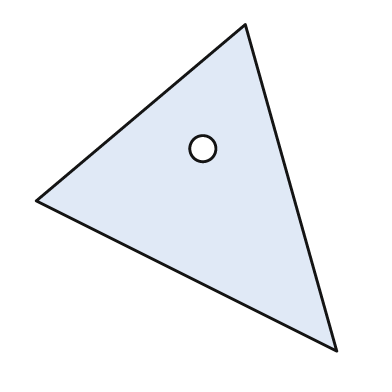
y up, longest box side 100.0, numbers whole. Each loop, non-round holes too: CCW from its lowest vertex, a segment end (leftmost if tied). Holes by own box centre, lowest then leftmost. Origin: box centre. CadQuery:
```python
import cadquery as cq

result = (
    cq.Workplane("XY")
    .moveTo(46.0, -50.0)
    .lineTo(18.0, 50.0)
    .lineTo(-46.0, -4.0)
    .close()
    .moveTo(5.0, 12.0)
    .circle(4.0)
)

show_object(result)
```